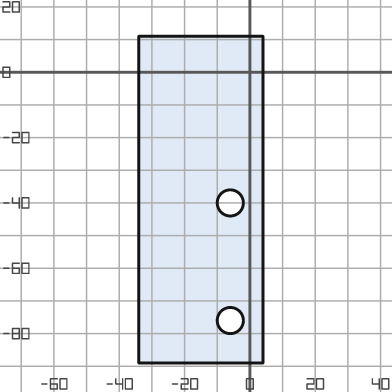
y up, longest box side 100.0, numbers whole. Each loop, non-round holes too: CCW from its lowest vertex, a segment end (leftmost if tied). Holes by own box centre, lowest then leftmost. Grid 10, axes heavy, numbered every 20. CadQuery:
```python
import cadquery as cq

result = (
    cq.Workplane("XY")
    .moveTo(-34.0, -89.0)
    .lineTo(4.0, -89.0)
    .lineTo(4.0, 11.0)
    .lineTo(-34.0, 11.0)
    .close()
    .moveTo(-6.0, -76.0)
    .circle(4.0)
    .moveTo(-6.0, -40.0)
    .circle(4.0)
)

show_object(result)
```